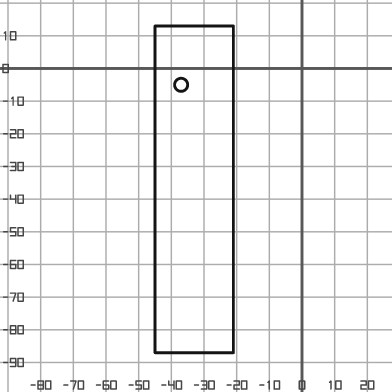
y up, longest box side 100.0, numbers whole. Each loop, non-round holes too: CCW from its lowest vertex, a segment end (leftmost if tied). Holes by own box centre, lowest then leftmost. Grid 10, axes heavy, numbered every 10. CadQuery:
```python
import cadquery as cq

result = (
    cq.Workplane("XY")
    .moveTo(-45.0, -87.0)
    .lineTo(-21.0, -87.0)
    .lineTo(-21.0, 13.0)
    .lineTo(-45.0, 13.0)
    .close()
    .moveTo(-37.0, -5.0)
    .circle(2.0)
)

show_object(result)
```